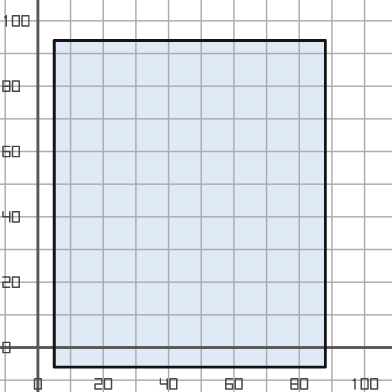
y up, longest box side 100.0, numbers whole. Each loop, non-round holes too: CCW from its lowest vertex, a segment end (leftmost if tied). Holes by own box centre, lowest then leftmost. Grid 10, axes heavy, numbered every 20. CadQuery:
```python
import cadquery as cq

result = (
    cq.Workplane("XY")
    .moveTo(5.0, -6.0)
    .lineTo(88.0, -6.0)
    .lineTo(88.0, 94.0)
    .lineTo(5.0, 94.0)
    .close()
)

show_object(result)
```